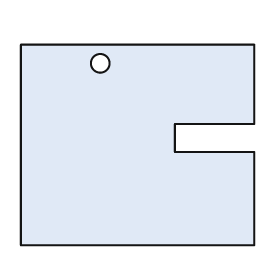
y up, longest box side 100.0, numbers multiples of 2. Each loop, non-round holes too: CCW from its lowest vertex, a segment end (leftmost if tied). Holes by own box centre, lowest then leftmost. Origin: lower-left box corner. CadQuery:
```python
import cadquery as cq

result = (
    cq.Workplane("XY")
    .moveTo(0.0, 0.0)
    .lineTo(100.0, 0.0)
    .lineTo(100.0, 40.0)
    .lineTo(66.0, 40.0)
    .lineTo(66.0, 52.0)
    .lineTo(100.0, 52.0)
    .lineTo(100.0, 86.0)
    .lineTo(0.0, 86.0)
    .close()
    .moveTo(34.0, 78.0)
    .circle(4.0)
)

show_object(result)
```